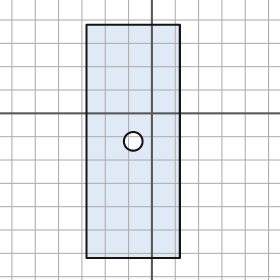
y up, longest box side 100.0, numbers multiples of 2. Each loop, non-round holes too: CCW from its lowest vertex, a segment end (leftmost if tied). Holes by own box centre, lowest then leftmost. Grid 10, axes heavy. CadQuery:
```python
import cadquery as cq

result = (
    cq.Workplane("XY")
    .moveTo(-28.0, -62.0)
    .lineTo(12.0, -62.0)
    .lineTo(12.0, 38.0)
    .lineTo(-28.0, 38.0)
    .close()
    .moveTo(-8.0, -12.0)
    .circle(4.0)
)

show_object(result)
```